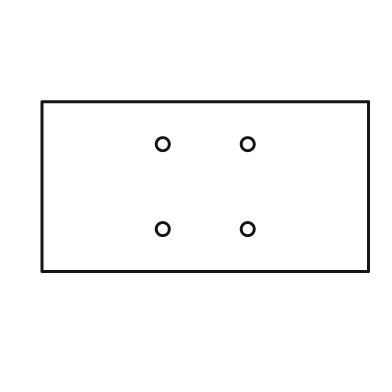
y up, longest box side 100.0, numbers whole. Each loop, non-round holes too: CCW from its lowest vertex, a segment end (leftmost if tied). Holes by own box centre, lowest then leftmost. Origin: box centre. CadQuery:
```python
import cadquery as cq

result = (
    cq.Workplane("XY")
    .moveTo(-50.0, -26.0)
    .lineTo(50.0, -26.0)
    .lineTo(50.0, 26.0)
    .lineTo(-50.0, 26.0)
    .close()
    .moveTo(-13.0, -13.0)
    .circle(2.0)
    .moveTo(13.0, -13.0)
    .circle(2.0)
    .moveTo(-13.0, 13.0)
    .circle(2.0)
    .moveTo(13.0, 13.0)
    .circle(2.0)
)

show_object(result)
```